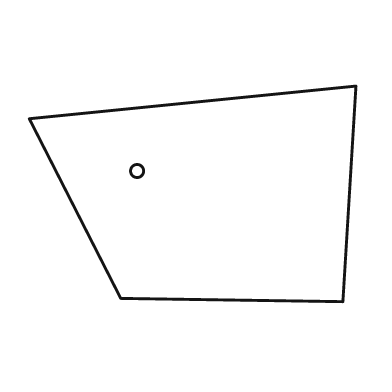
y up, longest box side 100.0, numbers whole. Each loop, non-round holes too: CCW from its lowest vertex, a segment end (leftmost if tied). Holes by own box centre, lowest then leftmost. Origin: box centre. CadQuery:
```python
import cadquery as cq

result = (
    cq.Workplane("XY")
    .moveTo(46.0, -33.0)
    .lineTo(50.0, 33.0)
    .lineTo(-50.0, 23.0)
    .lineTo(-22.0, -32.0)
    .close()
    .moveTo(-17.0, 7.0)
    .circle(2.0)
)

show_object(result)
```